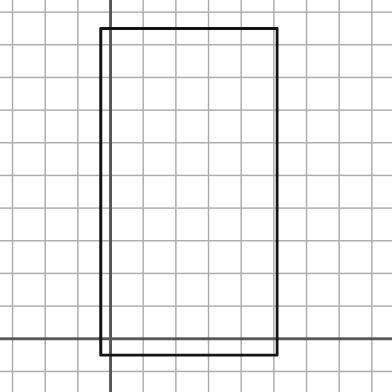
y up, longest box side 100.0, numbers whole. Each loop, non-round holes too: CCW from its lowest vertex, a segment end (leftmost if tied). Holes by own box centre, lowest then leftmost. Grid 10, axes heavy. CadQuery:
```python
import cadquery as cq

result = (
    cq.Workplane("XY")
    .moveTo(-3.0, -5.0)
    .lineTo(51.0, -5.0)
    .lineTo(51.0, 95.0)
    .lineTo(-3.0, 95.0)
    .close()
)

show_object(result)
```